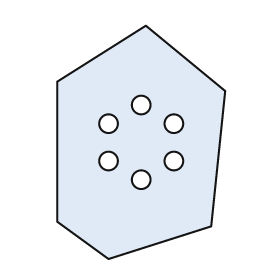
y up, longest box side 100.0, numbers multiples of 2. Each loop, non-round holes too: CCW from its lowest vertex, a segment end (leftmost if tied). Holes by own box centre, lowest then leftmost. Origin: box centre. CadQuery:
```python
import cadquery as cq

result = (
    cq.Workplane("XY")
    .moveTo(-14.0, -50.0)
    .lineTo(30.0, -36.0)
    .lineTo(36.0, 22.0)
    .lineTo(2.0, 50.0)
    .lineTo(-36.0, 26.0)
    .lineTo(-36.0, -34.0)
    .close()
    .moveTo(0.0, -16.0)
    .circle(4.0)
    .moveTo(-14.0, -8.0)
    .circle(4.0)
    .moveTo(14.0, -8.0)
    .circle(4.0)
    .moveTo(-14.0, 8.0)
    .circle(4.0)
    .moveTo(14.0, 8.0)
    .circle(4.0)
    .moveTo(0.0, 16.0)
    .circle(4.0)
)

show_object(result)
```